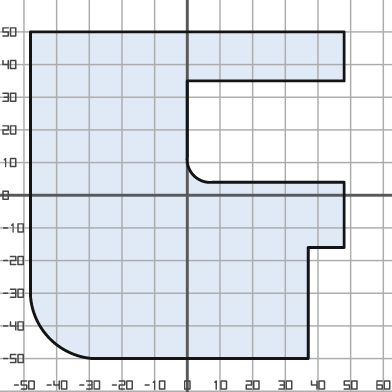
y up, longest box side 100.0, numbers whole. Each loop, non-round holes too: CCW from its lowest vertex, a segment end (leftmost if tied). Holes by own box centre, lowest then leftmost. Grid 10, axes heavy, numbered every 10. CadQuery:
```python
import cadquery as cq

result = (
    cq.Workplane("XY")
    .moveTo(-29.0, -50.0)
    .lineTo(37.0, -50.0)
    .lineTo(37.0, -16.0)
    .lineTo(48.0, -16.0)
    .lineTo(48.0, 4.0)
    .lineTo(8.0, 4.0)
    .threePointArc((2.0, 6.0), (0.0, 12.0))
    .lineTo(0.0, 35.0)
    .lineTo(48.0, 35.0)
    .lineTo(48.0, 50.0)
    .lineTo(-48.0, 50.0)
    .lineTo(-48.0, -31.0)
    .threePointArc((-42.0, -44.0), (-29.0, -50.0))
    .close()
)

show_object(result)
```